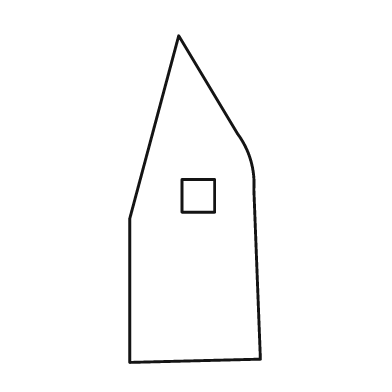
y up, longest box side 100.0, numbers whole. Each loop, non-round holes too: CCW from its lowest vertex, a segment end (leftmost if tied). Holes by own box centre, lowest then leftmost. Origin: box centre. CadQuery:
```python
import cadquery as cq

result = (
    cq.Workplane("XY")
    .moveTo(-20.0, -50.0)
    .lineTo(20.0, -49.0)
    .lineTo(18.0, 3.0)
    .threePointArc((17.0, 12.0), (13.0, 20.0))
    .lineTo(-5.0, 50.0)
    .lineTo(-20.0, -6.0)
    .close()
    .moveTo(-4.0, -4.0)
    .lineTo(6.0, -4.0)
    .lineTo(6.0, 6.0)
    .lineTo(-4.0, 6.0)
    .close()
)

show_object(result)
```